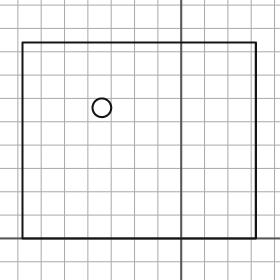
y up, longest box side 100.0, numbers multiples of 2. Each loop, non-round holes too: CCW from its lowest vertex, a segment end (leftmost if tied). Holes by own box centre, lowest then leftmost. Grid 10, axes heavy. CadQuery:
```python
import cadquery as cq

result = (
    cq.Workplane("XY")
    .moveTo(-68.0, 0.0)
    .lineTo(32.0, 0.0)
    .lineTo(32.0, 84.0)
    .lineTo(-68.0, 84.0)
    .close()
    .moveTo(-34.0, 56.0)
    .circle(4.0)
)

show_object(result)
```